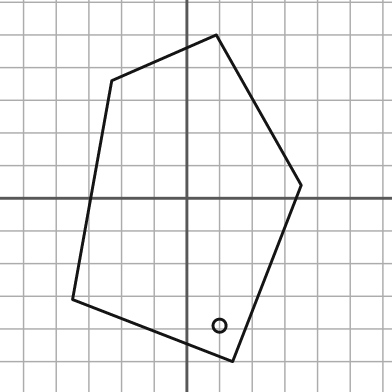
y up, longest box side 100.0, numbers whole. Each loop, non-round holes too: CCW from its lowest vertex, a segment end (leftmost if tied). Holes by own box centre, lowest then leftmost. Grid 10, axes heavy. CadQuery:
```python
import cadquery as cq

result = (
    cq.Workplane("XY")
    .moveTo(14.0, -50.0)
    .lineTo(35.0, 4.0)
    .lineTo(9.0, 50.0)
    .lineTo(-23.0, 36.0)
    .lineTo(-35.0, -31.0)
    .close()
    .moveTo(10.0, -39.0)
    .circle(2.0)
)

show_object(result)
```